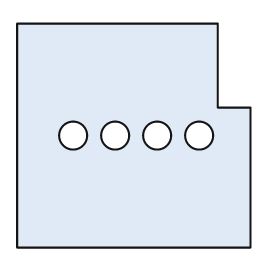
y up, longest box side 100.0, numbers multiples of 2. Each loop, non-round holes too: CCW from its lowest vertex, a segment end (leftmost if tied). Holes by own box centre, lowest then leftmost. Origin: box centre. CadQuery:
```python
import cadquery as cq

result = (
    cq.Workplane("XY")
    .moveTo(-50.0, -48.0)
    .lineTo(50.0, -48.0)
    .lineTo(50.0, 12.0)
    .lineTo(36.0, 12.0)
    .lineTo(36.0, 48.0)
    .lineTo(-50.0, 48.0)
    .close()
    .moveTo(-26.0, 0.0)
    .circle(6.0)
    .moveTo(-8.0, 0.0)
    .circle(6.0)
    .moveTo(10.0, 0.0)
    .circle(6.0)
    .moveTo(28.0, 0.0)
    .circle(6.0)
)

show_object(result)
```